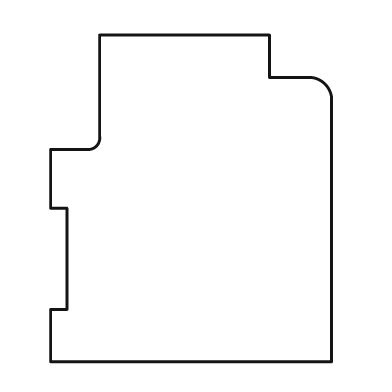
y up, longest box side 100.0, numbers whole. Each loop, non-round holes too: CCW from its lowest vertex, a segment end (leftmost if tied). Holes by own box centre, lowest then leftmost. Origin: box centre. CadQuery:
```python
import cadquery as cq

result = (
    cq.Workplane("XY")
    .moveTo(-43.0, -50.0)
    .lineTo(43.0, -50.0)
    .lineTo(43.0, 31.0)
    .threePointArc((41.0, 35.0), (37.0, 37.0))
    .lineTo(24.0, 37.0)
    .lineTo(24.0, 50.0)
    .lineTo(-28.0, 50.0)
    .lineTo(-28.0, 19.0)
    .threePointArc((-29.0, 16.0), (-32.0, 15.0))
    .lineTo(-43.0, 15.0)
    .lineTo(-43.0, -3.0)
    .lineTo(-38.0, -3.0)
    .lineTo(-38.0, -34.0)
    .lineTo(-43.0, -34.0)
    .close()
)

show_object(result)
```